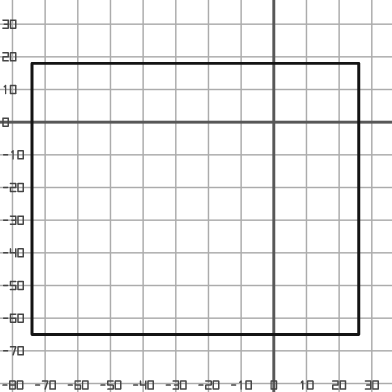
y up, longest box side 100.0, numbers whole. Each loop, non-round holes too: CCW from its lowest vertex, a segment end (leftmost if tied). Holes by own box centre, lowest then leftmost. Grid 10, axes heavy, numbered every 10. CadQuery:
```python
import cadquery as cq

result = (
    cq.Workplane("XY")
    .moveTo(-74.0, -65.0)
    .lineTo(26.0, -65.0)
    .lineTo(26.0, 18.0)
    .lineTo(-74.0, 18.0)
    .close()
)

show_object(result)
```